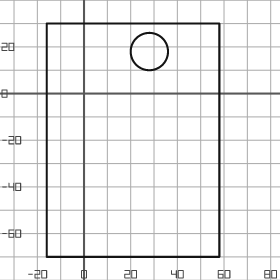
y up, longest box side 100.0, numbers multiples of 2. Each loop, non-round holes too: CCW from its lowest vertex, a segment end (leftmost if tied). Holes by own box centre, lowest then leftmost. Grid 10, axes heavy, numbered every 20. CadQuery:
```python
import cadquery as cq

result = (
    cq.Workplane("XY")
    .moveTo(-16.0, -70.0)
    .lineTo(58.0, -70.0)
    .lineTo(58.0, 30.0)
    .lineTo(-16.0, 30.0)
    .close()
    .moveTo(28.0, 18.0)
    .circle(8.0)
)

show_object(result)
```